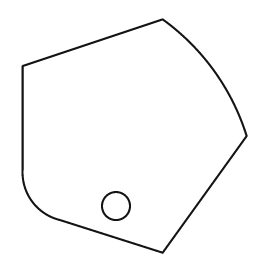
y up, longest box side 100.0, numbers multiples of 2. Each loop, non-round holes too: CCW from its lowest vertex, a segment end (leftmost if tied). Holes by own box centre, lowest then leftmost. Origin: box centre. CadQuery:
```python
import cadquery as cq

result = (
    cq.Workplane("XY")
    .moveTo(12.0, -50.0)
    .lineTo(48.0, 0.0)
    .threePointArc((34.0, 28.0), (12.0, 50.0))
    .lineTo(-48.0, 30.0)
    .lineTo(-48.0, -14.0)
    .threePointArc((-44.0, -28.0), (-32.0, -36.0))
    .close()
    .moveTo(-8.0, -30.0)
    .circle(6.0)
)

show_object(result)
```